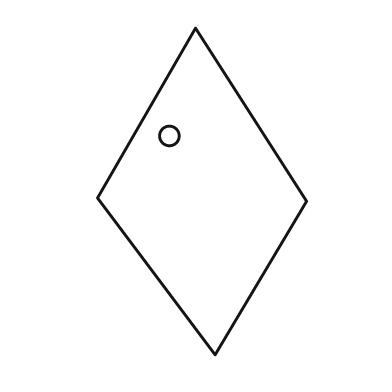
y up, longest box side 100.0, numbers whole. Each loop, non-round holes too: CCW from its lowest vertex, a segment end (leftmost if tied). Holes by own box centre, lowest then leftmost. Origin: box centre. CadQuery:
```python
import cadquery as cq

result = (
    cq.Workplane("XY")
    .moveTo(4.0, -50.0)
    .lineTo(32.0, -3.0)
    .lineTo(-2.0, 50.0)
    .lineTo(-32.0, -2.0)
    .close()
    .moveTo(-10.0, 17.0)
    .circle(3.0)
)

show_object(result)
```